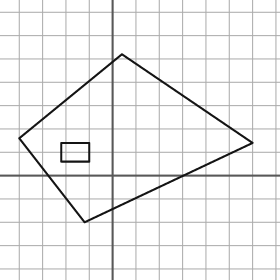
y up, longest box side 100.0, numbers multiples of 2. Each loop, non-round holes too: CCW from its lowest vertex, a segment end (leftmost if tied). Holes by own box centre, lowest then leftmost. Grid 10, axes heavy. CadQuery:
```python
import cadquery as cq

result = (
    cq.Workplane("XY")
    .moveTo(-12.0, -20.0)
    .lineTo(60.0, 14.0)
    .lineTo(4.0, 52.0)
    .lineTo(-40.0, 16.0)
    .close()
    .moveTo(-22.0, 6.0)
    .lineTo(-10.0, 6.0)
    .lineTo(-10.0, 14.0)
    .lineTo(-22.0, 14.0)
    .close()
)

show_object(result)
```